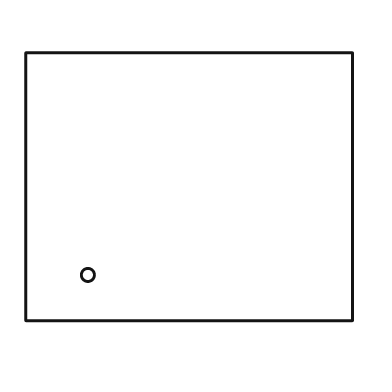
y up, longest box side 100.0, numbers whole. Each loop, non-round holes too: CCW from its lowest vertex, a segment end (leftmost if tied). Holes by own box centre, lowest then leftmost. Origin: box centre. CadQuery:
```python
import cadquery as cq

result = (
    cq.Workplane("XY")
    .moveTo(-50.0, -41.0)
    .lineTo(50.0, -41.0)
    .lineTo(50.0, 41.0)
    .lineTo(-50.0, 41.0)
    .close()
    .moveTo(-31.0, -27.0)
    .circle(2.0)
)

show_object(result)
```